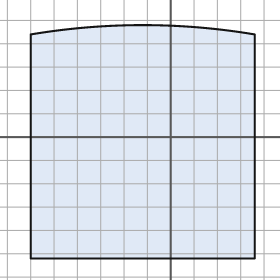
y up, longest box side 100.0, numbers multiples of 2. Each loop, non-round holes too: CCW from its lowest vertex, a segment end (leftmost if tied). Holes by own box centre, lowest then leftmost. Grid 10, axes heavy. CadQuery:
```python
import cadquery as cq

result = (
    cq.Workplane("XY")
    .moveTo(-60.0, -52.0)
    .lineTo(36.0, -52.0)
    .lineTo(36.0, 44.0)
    .threePointArc((-12.0, 48.0), (-60.0, 44.0))
    .close()
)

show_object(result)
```